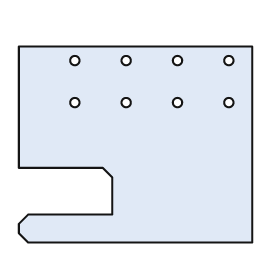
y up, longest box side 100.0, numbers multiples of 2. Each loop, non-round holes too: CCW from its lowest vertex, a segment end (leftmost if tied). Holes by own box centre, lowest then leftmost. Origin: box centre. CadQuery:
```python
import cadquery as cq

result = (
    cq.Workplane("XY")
    .moveTo(-46.0, -42.0)
    .lineTo(50.0, -42.0)
    .lineTo(50.0, 42.0)
    .lineTo(-50.0, 42.0)
    .lineTo(-50.0, -10.0)
    .lineTo(-14.0, -10.0)
    .lineTo(-10.0, -14.0)
    .lineTo(-10.0, -30.0)
    .lineTo(-46.0, -30.0)
    .lineTo(-50.0, -34.0)
    .lineTo(-50.0, -38.0)
    .close()
    .moveTo(-26.0, 18.0)
    .circle(2.0)
    .moveTo(-4.0, 18.0)
    .circle(2.0)
    .moveTo(18.0, 18.0)
    .circle(2.0)
    .moveTo(40.0, 18.0)
    .circle(2.0)
    .moveTo(-26.0, 36.0)
    .circle(2.0)
    .moveTo(-4.0, 36.0)
    .circle(2.0)
    .moveTo(18.0, 36.0)
    .circle(2.0)
    .moveTo(40.0, 36.0)
    .circle(2.0)
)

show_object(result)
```